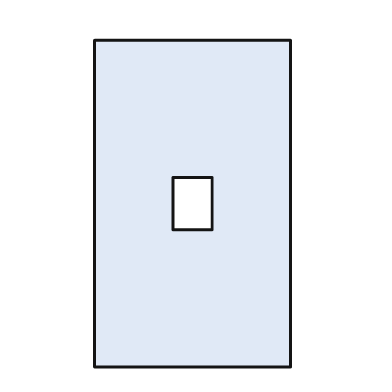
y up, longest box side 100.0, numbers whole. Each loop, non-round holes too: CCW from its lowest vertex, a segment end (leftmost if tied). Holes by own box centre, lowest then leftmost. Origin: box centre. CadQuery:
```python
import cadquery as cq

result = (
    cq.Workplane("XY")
    .moveTo(-30.0, -50.0)
    .lineTo(30.0, -50.0)
    .lineTo(30.0, 50.0)
    .lineTo(-30.0, 50.0)
    .close()
    .moveTo(-6.0, -8.0)
    .lineTo(6.0, -8.0)
    .lineTo(6.0, 8.0)
    .lineTo(-6.0, 8.0)
    .close()
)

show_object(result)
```